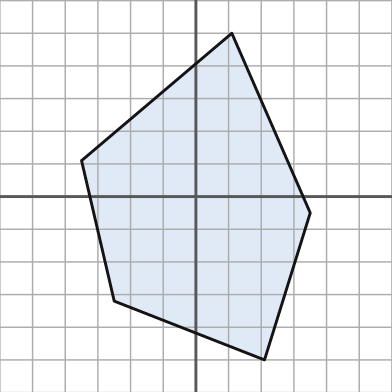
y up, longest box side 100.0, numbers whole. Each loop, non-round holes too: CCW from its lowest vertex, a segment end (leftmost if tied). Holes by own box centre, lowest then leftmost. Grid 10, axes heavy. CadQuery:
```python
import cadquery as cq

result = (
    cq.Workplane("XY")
    .moveTo(21.0, -50.0)
    .lineTo(35.0, -5.0)
    .lineTo(11.0, 50.0)
    .lineTo(-35.0, 11.0)
    .lineTo(-25.0, -32.0)
    .close()
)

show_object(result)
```